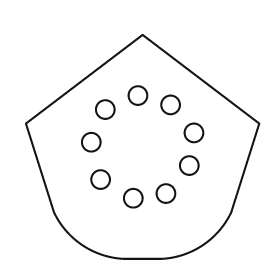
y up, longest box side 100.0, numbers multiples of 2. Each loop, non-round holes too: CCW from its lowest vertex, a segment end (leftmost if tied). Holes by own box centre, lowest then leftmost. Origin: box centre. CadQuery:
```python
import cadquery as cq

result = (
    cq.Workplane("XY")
    .moveTo(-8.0, -48.0)
    .lineTo(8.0, -48.0)
    .threePointArc((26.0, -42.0), (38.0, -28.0))
    .lineTo(50.0, 10.0)
    .lineTo(0.0, 48.0)
    .lineTo(-50.0, 10.0)
    .lineTo(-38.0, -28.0)
    .threePointArc((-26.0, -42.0), (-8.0, -48.0))
    .close()
    .moveTo(-4.0, -22.0)
    .circle(4.0)
    .moveTo(10.0, -20.0)
    .circle(4.0)
    .moveTo(-18.0, -14.0)
    .circle(4.0)
    .moveTo(20.0, -8.0)
    .circle(4.0)
    .moveTo(-22.0, 2.0)
    .circle(4.0)
    .moveTo(22.0, 6.0)
    .circle(4.0)
    .moveTo(-16.0, 16.0)
    .circle(4.0)
    .moveTo(12.0, 18.0)
    .circle(4.0)
    .moveTo(-2.0, 22.0)
    .circle(4.0)
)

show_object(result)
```